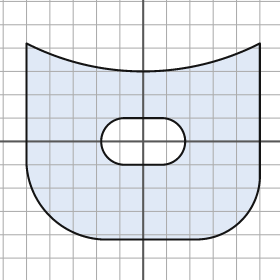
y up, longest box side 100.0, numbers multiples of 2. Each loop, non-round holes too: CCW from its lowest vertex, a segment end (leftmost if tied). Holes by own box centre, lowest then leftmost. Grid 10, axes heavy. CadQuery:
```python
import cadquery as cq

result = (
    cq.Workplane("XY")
    .moveTo(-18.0, -42.0)
    .lineTo(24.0, -42.0)
    .threePointArc((42.0, -34.0), (50.0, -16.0))
    .lineTo(50.0, 42.0)
    .threePointArc((0.0, 30.0), (-50.0, 42.0))
    .lineTo(-50.0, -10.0)
    .threePointArc((-40.0, -32.0), (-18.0, -42.0))
    .close()
    .moveTo(-8.0, -10.0)
    .lineTo(8.0, -10.0)
    .threePointArc((18.0, 0.0), (8.0, 10.0))
    .lineTo(-8.0, 10.0)
    .threePointArc((-18.0, 0.0), (-8.0, -10.0))
    .close()
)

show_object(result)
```